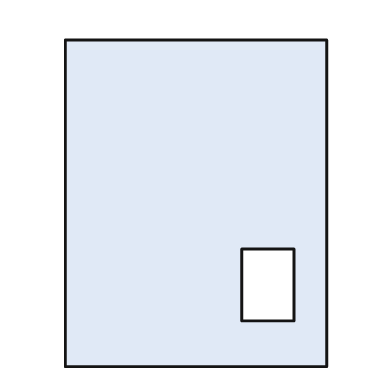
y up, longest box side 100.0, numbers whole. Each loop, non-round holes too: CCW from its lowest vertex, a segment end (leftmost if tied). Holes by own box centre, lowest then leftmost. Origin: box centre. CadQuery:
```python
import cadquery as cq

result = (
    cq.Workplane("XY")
    .moveTo(-40.0, -50.0)
    .lineTo(40.0, -50.0)
    .lineTo(40.0, 50.0)
    .lineTo(-40.0, 50.0)
    .close()
    .moveTo(14.0, -36.0)
    .lineTo(30.0, -36.0)
    .lineTo(30.0, -14.0)
    .lineTo(14.0, -14.0)
    .close()
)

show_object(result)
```